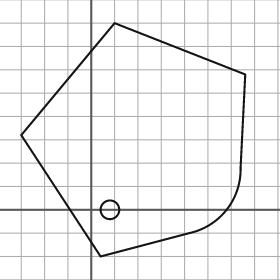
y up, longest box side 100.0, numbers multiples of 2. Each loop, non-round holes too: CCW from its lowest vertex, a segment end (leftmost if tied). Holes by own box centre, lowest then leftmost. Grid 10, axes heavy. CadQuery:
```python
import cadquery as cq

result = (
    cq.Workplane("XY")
    .moveTo(4.0, -20.0)
    .lineTo(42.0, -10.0)
    .threePointArc((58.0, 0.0), (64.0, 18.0))
    .lineTo(66.0, 58.0)
    .lineTo(10.0, 80.0)
    .lineTo(-30.0, 32.0)
    .close()
    .moveTo(8.0, 0.0)
    .circle(4.0)
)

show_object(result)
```